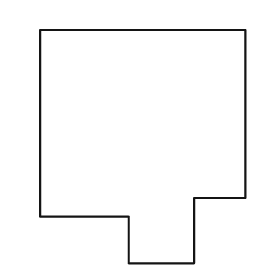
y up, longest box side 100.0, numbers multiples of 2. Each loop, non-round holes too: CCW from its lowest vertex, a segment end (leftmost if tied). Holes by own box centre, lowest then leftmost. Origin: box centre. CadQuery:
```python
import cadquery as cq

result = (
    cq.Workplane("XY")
    .moveTo(-6.0, -50.0)
    .lineTo(22.0, -50.0)
    .lineTo(22.0, -22.0)
    .lineTo(44.0, -22.0)
    .lineTo(44.0, 50.0)
    .lineTo(-44.0, 50.0)
    .lineTo(-44.0, -30.0)
    .lineTo(-6.0, -30.0)
    .close()
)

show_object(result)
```